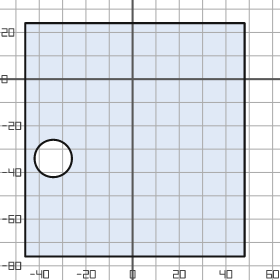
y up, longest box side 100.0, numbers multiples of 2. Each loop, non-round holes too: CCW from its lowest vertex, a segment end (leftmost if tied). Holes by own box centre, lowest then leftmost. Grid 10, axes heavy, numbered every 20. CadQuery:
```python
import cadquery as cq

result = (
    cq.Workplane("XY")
    .moveTo(-46.0, -76.0)
    .lineTo(48.0, -76.0)
    .lineTo(48.0, 24.0)
    .lineTo(-46.0, 24.0)
    .close()
    .moveTo(-34.0, -34.0)
    .circle(8.0)
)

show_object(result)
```